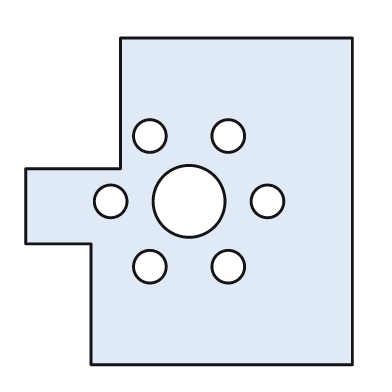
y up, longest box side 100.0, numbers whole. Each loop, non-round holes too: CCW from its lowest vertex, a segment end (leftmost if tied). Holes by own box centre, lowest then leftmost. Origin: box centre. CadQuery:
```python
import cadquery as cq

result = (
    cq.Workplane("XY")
    .moveTo(-30.0, -50.0)
    .lineTo(50.0, -50.0)
    .lineTo(50.0, 50.0)
    .lineTo(-21.0, 50.0)
    .lineTo(-21.0, 10.0)
    .lineTo(-50.0, 10.0)
    .lineTo(-50.0, -13.0)
    .lineTo(-30.0, -13.0)
    .close()
    .moveTo(-12.0, -20.0)
    .circle(5.0)
    .moveTo(12.0, -20.0)
    .circle(5.0)
    .moveTo(-24.0, 0.0)
    .circle(5.0)
    .moveTo(0.0, 0.0)
    .circle(11.0)
    .moveTo(24.0, 0.0)
    .circle(5.0)
    .moveTo(-12.0, 20.0)
    .circle(5.0)
    .moveTo(12.0, 20.0)
    .circle(5.0)
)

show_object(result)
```